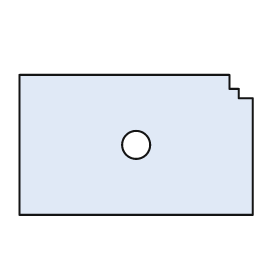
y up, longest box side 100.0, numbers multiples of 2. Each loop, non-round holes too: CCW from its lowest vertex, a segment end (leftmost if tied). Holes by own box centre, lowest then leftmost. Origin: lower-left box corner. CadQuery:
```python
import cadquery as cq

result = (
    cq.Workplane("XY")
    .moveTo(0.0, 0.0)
    .lineTo(100.0, 0.0)
    .lineTo(100.0, 50.0)
    .lineTo(94.0, 50.0)
    .lineTo(94.0, 54.0)
    .lineTo(90.0, 54.0)
    .lineTo(90.0, 60.0)
    .lineTo(0.0, 60.0)
    .close()
    .moveTo(50.0, 30.0)
    .circle(6.0)
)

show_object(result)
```